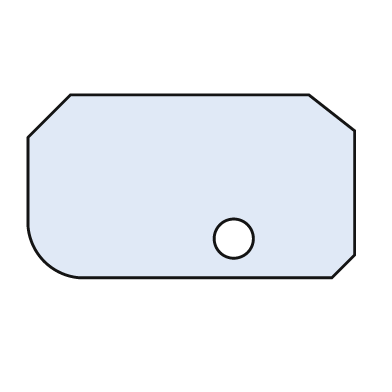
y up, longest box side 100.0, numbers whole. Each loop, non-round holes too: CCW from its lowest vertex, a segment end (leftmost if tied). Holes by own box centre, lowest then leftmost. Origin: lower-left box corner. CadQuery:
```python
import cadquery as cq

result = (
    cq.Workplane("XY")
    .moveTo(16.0, 0.0)
    .lineTo(93.0, 0.0)
    .lineTo(100.0, 7.0)
    .lineTo(100.0, 45.0)
    .lineTo(86.0, 56.0)
    .lineTo(13.0, 56.0)
    .lineTo(0.0, 43.0)
    .lineTo(0.0, 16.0)
    .threePointArc((5.0, 5.0), (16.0, 0.0))
    .close()
    .moveTo(63.0, 12.0)
    .circle(6.0)
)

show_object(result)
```